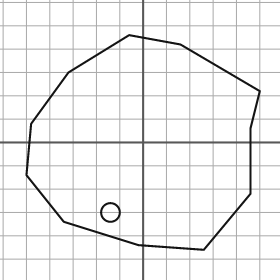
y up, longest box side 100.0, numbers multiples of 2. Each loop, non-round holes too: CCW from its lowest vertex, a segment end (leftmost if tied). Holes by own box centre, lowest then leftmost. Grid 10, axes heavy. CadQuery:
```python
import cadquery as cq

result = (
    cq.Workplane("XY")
    .moveTo(26.0, -46.0)
    .lineTo(46.0, -22.0)
    .lineTo(46.0, 6.0)
    .lineTo(50.0, 22.0)
    .lineTo(16.0, 42.0)
    .lineTo(-6.0, 46.0)
    .lineTo(-32.0, 30.0)
    .lineTo(-48.0, 8.0)
    .lineTo(-50.0, -14.0)
    .lineTo(-34.0, -34.0)
    .lineTo(-2.0, -44.0)
    .close()
    .moveTo(-14.0, -30.0)
    .circle(4.0)
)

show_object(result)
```